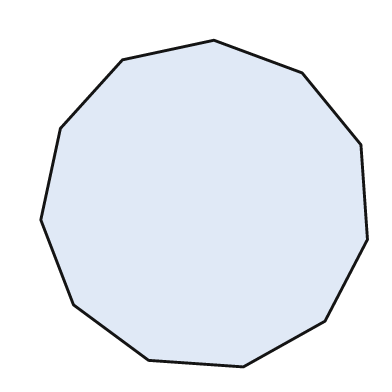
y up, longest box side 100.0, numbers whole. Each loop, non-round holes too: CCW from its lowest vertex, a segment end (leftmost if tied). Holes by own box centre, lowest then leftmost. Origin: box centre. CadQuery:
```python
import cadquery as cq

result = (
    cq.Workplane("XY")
    .moveTo(12.0, -50.0)
    .lineTo(37.0, -36.0)
    .lineTo(50.0, -11.0)
    .lineTo(48.0, 18.0)
    .lineTo(30.0, 40.0)
    .lineTo(3.0, 50.0)
    .lineTo(-25.0, 44.0)
    .lineTo(-44.0, 23.0)
    .lineTo(-50.0, -5.0)
    .lineTo(-40.0, -31.0)
    .lineTo(-17.0, -48.0)
    .close()
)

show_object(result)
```